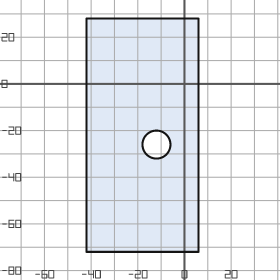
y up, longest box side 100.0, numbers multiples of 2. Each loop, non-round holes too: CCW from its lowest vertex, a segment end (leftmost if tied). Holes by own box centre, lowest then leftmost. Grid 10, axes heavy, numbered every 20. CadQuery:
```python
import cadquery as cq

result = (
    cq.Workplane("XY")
    .moveTo(-42.0, -72.0)
    .lineTo(6.0, -72.0)
    .lineTo(6.0, 28.0)
    .lineTo(-42.0, 28.0)
    .close()
    .moveTo(-12.0, -26.0)
    .circle(6.0)
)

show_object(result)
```